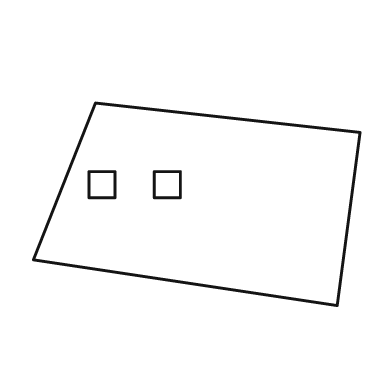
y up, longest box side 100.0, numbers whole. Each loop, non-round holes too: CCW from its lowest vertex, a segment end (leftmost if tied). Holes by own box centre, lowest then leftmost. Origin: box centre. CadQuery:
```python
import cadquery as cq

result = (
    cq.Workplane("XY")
    .moveTo(43.0, -31.0)
    .lineTo(50.0, 22.0)
    .lineTo(-31.0, 31.0)
    .lineTo(-50.0, -17.0)
    .close()
    .moveTo(-33.0, 2.0)
    .lineTo(-25.0, 2.0)
    .lineTo(-25.0, 10.0)
    .lineTo(-33.0, 10.0)
    .close()
    .moveTo(-13.0, 2.0)
    .lineTo(-5.0, 2.0)
    .lineTo(-5.0, 10.0)
    .lineTo(-13.0, 10.0)
    .close()
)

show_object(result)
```